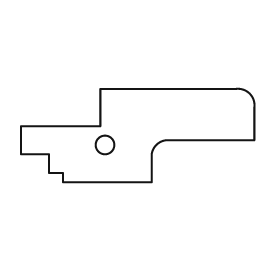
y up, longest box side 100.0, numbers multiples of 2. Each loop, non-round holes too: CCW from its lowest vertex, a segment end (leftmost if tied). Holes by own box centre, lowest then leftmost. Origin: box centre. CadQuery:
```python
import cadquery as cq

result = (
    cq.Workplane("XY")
    .moveTo(-32.0, -20.0)
    .lineTo(6.0, -20.0)
    .lineTo(6.0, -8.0)
    .threePointArc((8.0, -4.0), (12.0, -2.0))
    .lineTo(50.0, -2.0)
    .lineTo(50.0, 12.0)
    .threePointArc((48.0, 18.0), (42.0, 20.0))
    .lineTo(-16.0, 20.0)
    .lineTo(-16.0, 4.0)
    .lineTo(-50.0, 4.0)
    .lineTo(-50.0, -8.0)
    .lineTo(-38.0, -8.0)
    .lineTo(-38.0, -16.0)
    .lineTo(-32.0, -16.0)
    .close()
    .moveTo(-14.0, -4.0)
    .circle(4.0)
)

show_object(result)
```